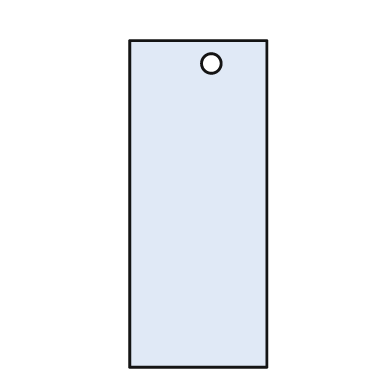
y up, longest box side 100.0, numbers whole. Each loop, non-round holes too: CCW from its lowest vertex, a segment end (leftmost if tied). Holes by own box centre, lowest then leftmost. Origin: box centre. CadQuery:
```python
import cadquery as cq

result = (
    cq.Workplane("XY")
    .moveTo(-21.0, -50.0)
    .lineTo(21.0, -50.0)
    .lineTo(21.0, 50.0)
    .lineTo(-21.0, 50.0)
    .close()
    .moveTo(4.0, 43.0)
    .circle(3.0)
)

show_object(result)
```